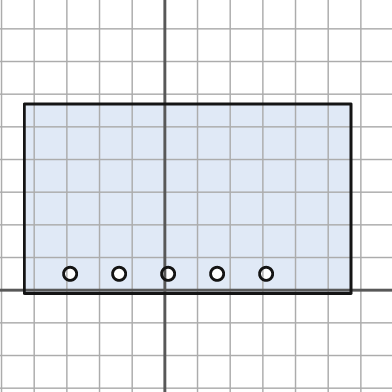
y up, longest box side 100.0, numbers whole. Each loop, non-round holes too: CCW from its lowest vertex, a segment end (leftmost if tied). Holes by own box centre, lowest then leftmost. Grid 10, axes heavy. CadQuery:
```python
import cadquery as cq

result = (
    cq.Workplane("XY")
    .moveTo(-43.0, -1.0)
    .lineTo(57.0, -1.0)
    .lineTo(57.0, 57.0)
    .lineTo(-43.0, 57.0)
    .close()
    .moveTo(-29.0, 5.0)
    .circle(2.0)
    .moveTo(-14.0, 5.0)
    .circle(2.0)
    .moveTo(1.0, 5.0)
    .circle(2.0)
    .moveTo(16.0, 5.0)
    .circle(2.0)
    .moveTo(31.0, 5.0)
    .circle(2.0)
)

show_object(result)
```